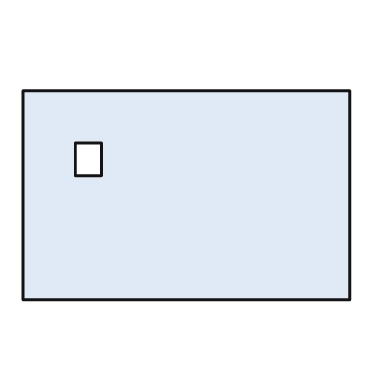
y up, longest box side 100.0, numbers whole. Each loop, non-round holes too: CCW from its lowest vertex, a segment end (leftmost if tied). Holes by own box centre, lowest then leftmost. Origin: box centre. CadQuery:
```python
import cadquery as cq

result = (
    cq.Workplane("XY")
    .moveTo(-50.0, -32.0)
    .lineTo(50.0, -32.0)
    .lineTo(50.0, 32.0)
    .lineTo(-50.0, 32.0)
    .close()
    .moveTo(-34.0, 6.0)
    .lineTo(-26.0, 6.0)
    .lineTo(-26.0, 16.0)
    .lineTo(-34.0, 16.0)
    .close()
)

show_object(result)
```